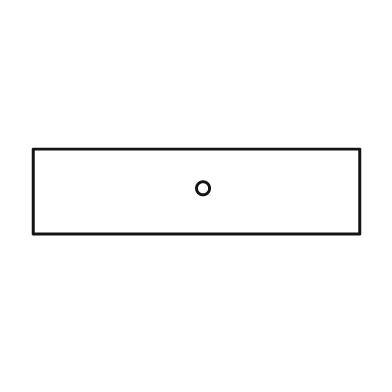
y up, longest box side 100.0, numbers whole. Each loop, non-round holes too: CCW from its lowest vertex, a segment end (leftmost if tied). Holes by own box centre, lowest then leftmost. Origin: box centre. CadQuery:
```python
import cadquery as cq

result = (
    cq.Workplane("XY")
    .moveTo(-50.0, -13.0)
    .lineTo(50.0, -13.0)
    .lineTo(50.0, 13.0)
    .lineTo(-50.0, 13.0)
    .close()
    .moveTo(2.0, 1.0)
    .circle(2.0)
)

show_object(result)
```